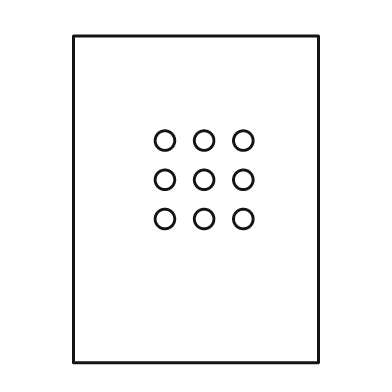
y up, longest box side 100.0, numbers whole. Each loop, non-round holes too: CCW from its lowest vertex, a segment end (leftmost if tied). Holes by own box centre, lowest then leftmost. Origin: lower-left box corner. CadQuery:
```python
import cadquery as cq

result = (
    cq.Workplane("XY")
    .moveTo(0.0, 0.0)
    .lineTo(75.0, 0.0)
    .lineTo(75.0, 100.0)
    .lineTo(0.0, 100.0)
    .close()
    .moveTo(28.0, 44.0)
    .circle(3.0)
    .moveTo(40.0, 44.0)
    .circle(3.0)
    .moveTo(52.0, 44.0)
    .circle(3.0)
    .moveTo(28.0, 56.0)
    .circle(3.0)
    .moveTo(40.0, 56.0)
    .circle(3.0)
    .moveTo(52.0, 56.0)
    .circle(3.0)
    .moveTo(28.0, 68.0)
    .circle(3.0)
    .moveTo(40.0, 68.0)
    .circle(3.0)
    .moveTo(52.0, 68.0)
    .circle(3.0)
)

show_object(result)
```